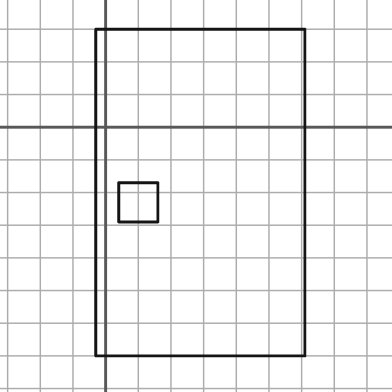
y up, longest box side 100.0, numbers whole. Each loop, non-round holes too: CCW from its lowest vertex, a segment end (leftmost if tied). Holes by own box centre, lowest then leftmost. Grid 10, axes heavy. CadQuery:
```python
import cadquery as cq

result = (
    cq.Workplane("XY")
    .moveTo(-3.0, -70.0)
    .lineTo(61.0, -70.0)
    .lineTo(61.0, 30.0)
    .lineTo(-3.0, 30.0)
    .close()
    .moveTo(4.0, -29.0)
    .lineTo(16.0, -29.0)
    .lineTo(16.0, -17.0)
    .lineTo(4.0, -17.0)
    .close()
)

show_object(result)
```